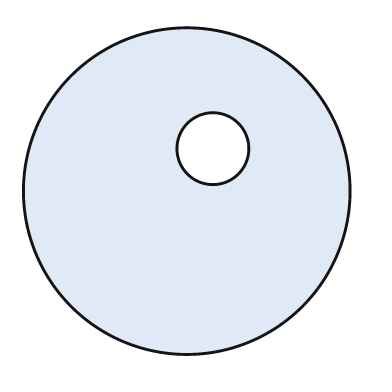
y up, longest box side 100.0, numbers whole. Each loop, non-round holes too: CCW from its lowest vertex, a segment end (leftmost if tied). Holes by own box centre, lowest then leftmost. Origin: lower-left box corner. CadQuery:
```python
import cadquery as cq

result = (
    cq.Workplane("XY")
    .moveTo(50.0, 50.0)
    .circle(50.0)
    .moveTo(58.0, 63.0)
    .circle(11.0)
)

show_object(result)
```